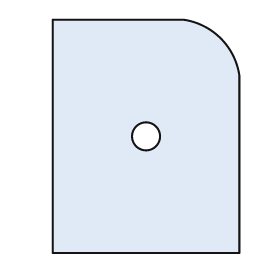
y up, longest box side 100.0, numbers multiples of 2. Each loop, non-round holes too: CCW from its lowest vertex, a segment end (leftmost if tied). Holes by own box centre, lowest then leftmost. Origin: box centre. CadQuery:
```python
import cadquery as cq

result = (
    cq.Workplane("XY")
    .moveTo(-40.0, -50.0)
    .lineTo(40.0, -50.0)
    .lineTo(40.0, 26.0)
    .threePointArc((32.0, 42.0), (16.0, 50.0))
    .lineTo(-40.0, 50.0)
    .close()
    .moveTo(0.0, 0.0)
    .circle(6.0)
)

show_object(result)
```